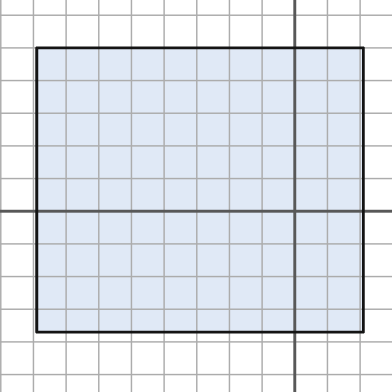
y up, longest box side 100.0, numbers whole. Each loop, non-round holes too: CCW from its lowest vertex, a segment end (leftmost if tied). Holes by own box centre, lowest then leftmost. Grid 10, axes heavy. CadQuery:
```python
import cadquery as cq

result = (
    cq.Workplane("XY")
    .moveTo(-79.0, -37.0)
    .lineTo(21.0, -37.0)
    .lineTo(21.0, 50.0)
    .lineTo(-79.0, 50.0)
    .close()
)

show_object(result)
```